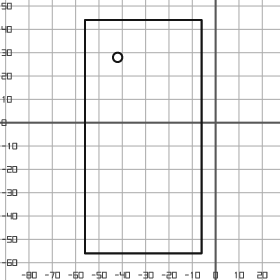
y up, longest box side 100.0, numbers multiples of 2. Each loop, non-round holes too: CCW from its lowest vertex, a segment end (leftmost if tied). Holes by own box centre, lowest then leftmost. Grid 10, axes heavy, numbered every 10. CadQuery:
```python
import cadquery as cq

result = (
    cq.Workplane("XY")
    .moveTo(-56.0, -56.0)
    .lineTo(-6.0, -56.0)
    .lineTo(-6.0, 44.0)
    .lineTo(-56.0, 44.0)
    .close()
    .moveTo(-42.0, 28.0)
    .circle(2.0)
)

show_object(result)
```